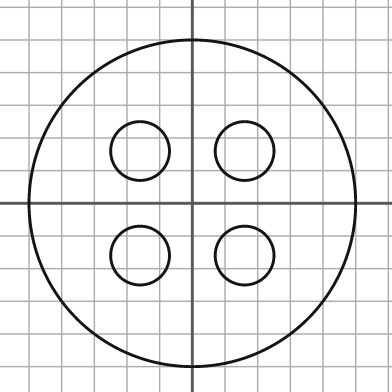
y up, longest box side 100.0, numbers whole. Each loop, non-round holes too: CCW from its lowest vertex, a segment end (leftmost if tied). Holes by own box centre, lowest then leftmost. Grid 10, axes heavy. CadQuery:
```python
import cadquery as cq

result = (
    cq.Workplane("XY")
    .moveTo(0.0, 0.0)
    .circle(50.0)
    .moveTo(-16.0, -16.0)
    .circle(9.0)
    .moveTo(16.0, -16.0)
    .circle(9.0)
    .moveTo(-16.0, 16.0)
    .circle(9.0)
    .moveTo(16.0, 16.0)
    .circle(9.0)
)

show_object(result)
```